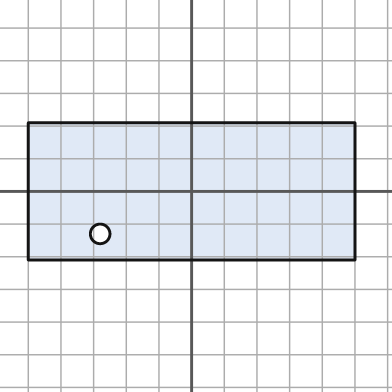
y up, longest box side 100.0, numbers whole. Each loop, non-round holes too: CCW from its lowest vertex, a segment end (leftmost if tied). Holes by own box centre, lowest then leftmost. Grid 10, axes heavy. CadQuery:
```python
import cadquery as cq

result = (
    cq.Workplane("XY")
    .moveTo(-50.0, -21.0)
    .lineTo(50.0, -21.0)
    .lineTo(50.0, 21.0)
    .lineTo(-50.0, 21.0)
    .close()
    .moveTo(-28.0, -13.0)
    .circle(3.0)
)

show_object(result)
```